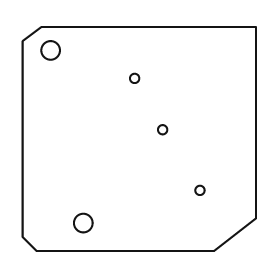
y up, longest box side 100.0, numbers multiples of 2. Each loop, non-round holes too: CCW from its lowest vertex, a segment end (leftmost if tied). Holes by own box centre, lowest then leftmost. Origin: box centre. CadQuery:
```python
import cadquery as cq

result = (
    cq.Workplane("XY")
    .moveTo(-44.0, -48.0)
    .lineTo(32.0, -48.0)
    .lineTo(50.0, -34.0)
    .lineTo(50.0, 48.0)
    .lineTo(-42.0, 48.0)
    .lineTo(-50.0, 42.0)
    .lineTo(-50.0, -42.0)
    .close()
    .moveTo(-24.0, -36.0)
    .circle(4.0)
    .moveTo(26.0, -22.0)
    .circle(2.0)
    .moveTo(10.0, 4.0)
    .circle(2.0)
    .moveTo(-2.0, 26.0)
    .circle(2.0)
    .moveTo(-38.0, 38.0)
    .circle(4.0)
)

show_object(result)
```